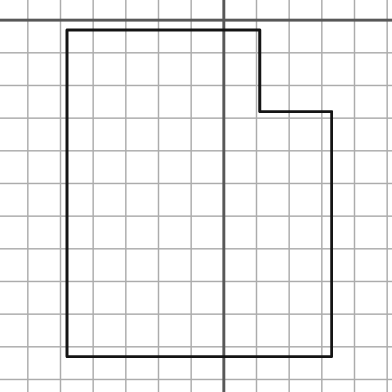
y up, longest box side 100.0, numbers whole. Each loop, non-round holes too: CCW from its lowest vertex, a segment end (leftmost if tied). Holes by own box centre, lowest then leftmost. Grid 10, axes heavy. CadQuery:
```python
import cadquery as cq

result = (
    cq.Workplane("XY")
    .moveTo(-48.0, -103.0)
    .lineTo(33.0, -103.0)
    .lineTo(33.0, -28.0)
    .lineTo(11.0, -28.0)
    .lineTo(11.0, -3.0)
    .lineTo(-48.0, -3.0)
    .close()
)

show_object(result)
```